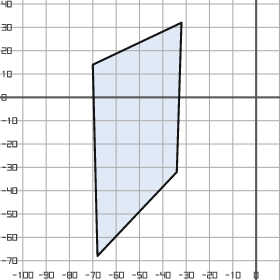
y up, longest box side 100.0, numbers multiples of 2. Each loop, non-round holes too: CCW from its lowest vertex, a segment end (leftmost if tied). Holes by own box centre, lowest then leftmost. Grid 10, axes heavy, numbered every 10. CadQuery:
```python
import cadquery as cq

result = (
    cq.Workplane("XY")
    .moveTo(-68.0, -68.0)
    .lineTo(-34.0, -32.0)
    .lineTo(-32.0, 32.0)
    .lineTo(-70.0, 14.0)
    .close()
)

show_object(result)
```